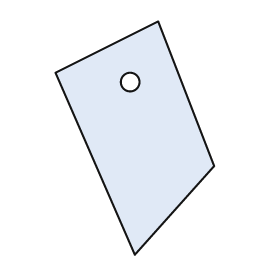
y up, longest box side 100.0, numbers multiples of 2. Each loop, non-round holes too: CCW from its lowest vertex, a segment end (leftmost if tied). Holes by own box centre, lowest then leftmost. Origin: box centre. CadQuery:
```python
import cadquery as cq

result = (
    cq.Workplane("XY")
    .moveTo(0.0, -50.0)
    .lineTo(34.0, -12.0)
    .lineTo(10.0, 50.0)
    .lineTo(-34.0, 28.0)
    .close()
    .moveTo(-2.0, 24.0)
    .circle(4.0)
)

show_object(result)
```